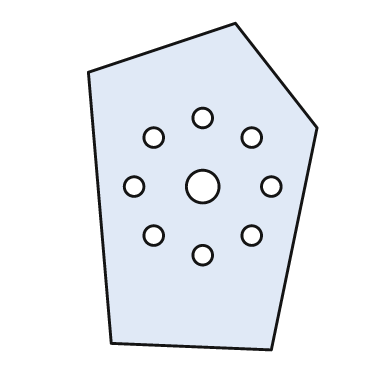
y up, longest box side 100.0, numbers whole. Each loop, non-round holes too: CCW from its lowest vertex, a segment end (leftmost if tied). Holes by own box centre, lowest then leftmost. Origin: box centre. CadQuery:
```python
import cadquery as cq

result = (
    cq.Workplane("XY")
    .moveTo(21.0, -50.0)
    .lineTo(35.0, 18.0)
    .lineTo(10.0, 50.0)
    .lineTo(-35.0, 35.0)
    .lineTo(-28.0, -48.0)
    .close()
    .moveTo(0.0, -21.0)
    .circle(3.0)
    .moveTo(-15.0, -15.0)
    .circle(3.0)
    .moveTo(15.0, -15.0)
    .circle(3.0)
    .moveTo(-21.0, 0.0)
    .circle(3.0)
    .moveTo(0.0, 0.0)
    .circle(5.0)
    .moveTo(21.0, 0.0)
    .circle(3.0)
    .moveTo(-15.0, 15.0)
    .circle(3.0)
    .moveTo(15.0, 15.0)
    .circle(3.0)
    .moveTo(0.0, 21.0)
    .circle(3.0)
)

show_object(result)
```